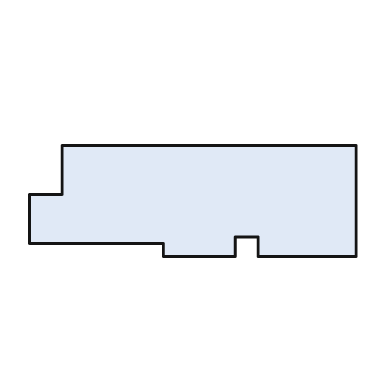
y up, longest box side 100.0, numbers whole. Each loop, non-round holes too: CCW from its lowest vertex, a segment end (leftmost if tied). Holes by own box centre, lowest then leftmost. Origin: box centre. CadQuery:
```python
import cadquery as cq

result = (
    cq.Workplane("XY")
    .moveTo(-9.0, -17.0)
    .lineTo(13.0, -17.0)
    .lineTo(13.0, -11.0)
    .lineTo(20.0, -11.0)
    .lineTo(20.0, -17.0)
    .lineTo(50.0, -17.0)
    .lineTo(50.0, 17.0)
    .lineTo(-40.0, 17.0)
    .lineTo(-40.0, 2.0)
    .lineTo(-50.0, 2.0)
    .lineTo(-50.0, -13.0)
    .lineTo(-9.0, -13.0)
    .close()
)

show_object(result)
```